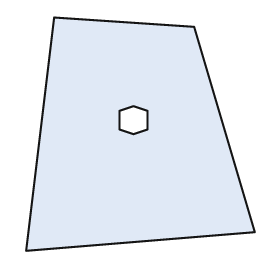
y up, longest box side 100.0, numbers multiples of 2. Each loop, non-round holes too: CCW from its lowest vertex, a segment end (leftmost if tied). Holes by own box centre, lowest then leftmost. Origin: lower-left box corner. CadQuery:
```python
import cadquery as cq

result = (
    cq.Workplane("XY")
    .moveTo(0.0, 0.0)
    .lineTo(98.0, 8.0)
    .lineTo(72.0, 96.0)
    .lineTo(12.0, 100.0)
    .close()
    .moveTo(46.0, 50.0)
    .lineTo(52.0, 52.0)
    .lineTo(52.0, 60.0)
    .lineTo(46.0, 62.0)
    .lineTo(40.0, 60.0)
    .lineTo(40.0, 52.0)
    .close()
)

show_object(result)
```